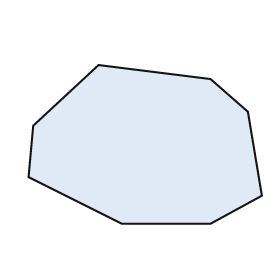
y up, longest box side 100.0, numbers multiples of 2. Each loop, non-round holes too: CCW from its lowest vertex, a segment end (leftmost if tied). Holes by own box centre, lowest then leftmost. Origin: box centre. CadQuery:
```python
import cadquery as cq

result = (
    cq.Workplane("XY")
    .moveTo(-10.0, -34.0)
    .lineTo(28.0, -34.0)
    .lineTo(50.0, -22.0)
    .lineTo(44.0, 14.0)
    .lineTo(28.0, 28.0)
    .lineTo(-20.0, 34.0)
    .lineTo(-48.0, 8.0)
    .lineTo(-50.0, -14.0)
    .close()
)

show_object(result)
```